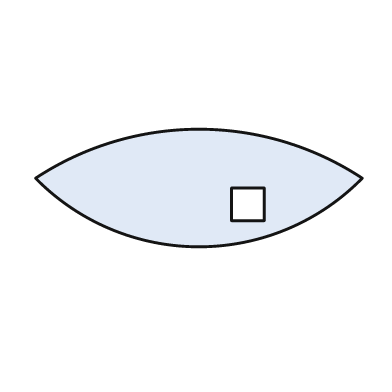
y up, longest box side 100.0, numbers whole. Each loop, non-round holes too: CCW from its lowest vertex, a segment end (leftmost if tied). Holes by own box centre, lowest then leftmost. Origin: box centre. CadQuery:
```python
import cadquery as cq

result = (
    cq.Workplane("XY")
    .moveTo(-50.0, 3.0)
    .threePointArc((0.0, -18.0), (50.0, 3.0))
    .threePointArc((0.0, 18.0), (-50.0, 3.0))
    .close()
    .moveTo(10.0, -10.0)
    .lineTo(20.0, -10.0)
    .lineTo(20.0, 0.0)
    .lineTo(10.0, 0.0)
    .close()
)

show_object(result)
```